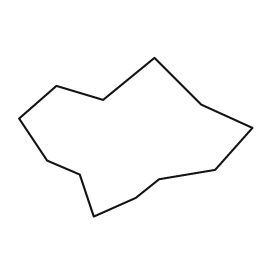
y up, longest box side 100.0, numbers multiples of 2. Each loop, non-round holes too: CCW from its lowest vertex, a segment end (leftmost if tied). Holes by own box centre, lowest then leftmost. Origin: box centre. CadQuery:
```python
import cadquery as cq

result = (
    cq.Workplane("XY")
    .moveTo(-18.0, -34.0)
    .lineTo(0.0, -26.0)
    .lineTo(10.0, -18.0)
    .lineTo(34.0, -14.0)
    .lineTo(50.0, 4.0)
    .lineTo(28.0, 14.0)
    .lineTo(8.0, 34.0)
    .lineTo(-14.0, 16.0)
    .lineTo(-34.0, 22.0)
    .lineTo(-50.0, 8.0)
    .lineTo(-38.0, -10.0)
    .lineTo(-24.0, -16.0)
    .close()
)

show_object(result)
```